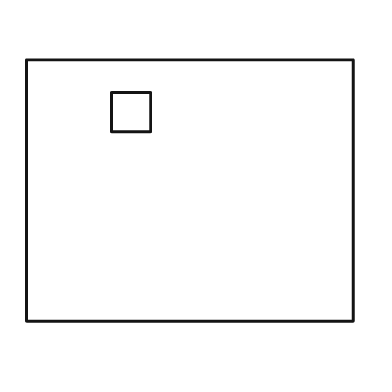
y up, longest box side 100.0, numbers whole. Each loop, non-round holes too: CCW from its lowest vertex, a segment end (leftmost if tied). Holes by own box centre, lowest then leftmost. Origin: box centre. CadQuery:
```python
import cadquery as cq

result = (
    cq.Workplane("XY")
    .moveTo(-50.0, -40.0)
    .lineTo(50.0, -40.0)
    .lineTo(50.0, 40.0)
    .lineTo(-50.0, 40.0)
    .close()
    .moveTo(-24.0, 18.0)
    .lineTo(-12.0, 18.0)
    .lineTo(-12.0, 30.0)
    .lineTo(-24.0, 30.0)
    .close()
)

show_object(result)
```